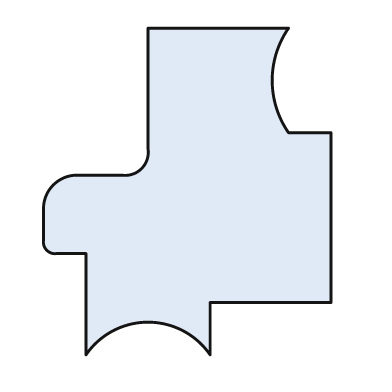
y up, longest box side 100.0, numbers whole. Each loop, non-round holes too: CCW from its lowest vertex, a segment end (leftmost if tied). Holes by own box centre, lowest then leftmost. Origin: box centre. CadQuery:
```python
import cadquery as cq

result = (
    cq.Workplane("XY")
    .moveTo(-31.0, -50.0)
    .threePointArc((-12.0, -40.0), (7.0, -50.0))
    .lineTo(7.0, -34.0)
    .lineTo(44.0, -34.0)
    .lineTo(44.0, 18.0)
    .lineTo(31.0, 18.0)
    .threePointArc((26.0, 34.0), (31.0, 50.0))
    .lineTo(-12.0, 50.0)
    .lineTo(-12.0, 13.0)
    .threePointArc((-14.0, 7.0), (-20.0, 5.0))
    .lineTo(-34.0, 5.0)
    .threePointArc((-41.0, 2.0), (-44.0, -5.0))
    .lineTo(-44.0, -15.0)
    .threePointArc((-43.0, -18.0), (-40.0, -19.0))
    .lineTo(-31.0, -19.0)
    .close()
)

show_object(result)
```